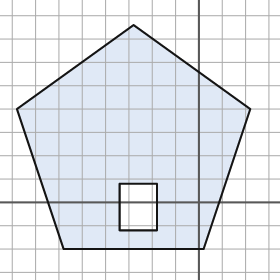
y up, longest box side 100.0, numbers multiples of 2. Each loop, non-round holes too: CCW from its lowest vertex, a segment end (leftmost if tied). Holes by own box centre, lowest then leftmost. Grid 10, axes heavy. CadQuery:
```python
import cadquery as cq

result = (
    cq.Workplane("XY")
    .moveTo(-58.0, -20.0)
    .lineTo(2.0, -20.0)
    .lineTo(22.0, 40.0)
    .lineTo(-28.0, 76.0)
    .lineTo(-78.0, 40.0)
    .close()
    .moveTo(-34.0, -12.0)
    .lineTo(-18.0, -12.0)
    .lineTo(-18.0, 8.0)
    .lineTo(-34.0, 8.0)
    .close()
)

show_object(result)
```